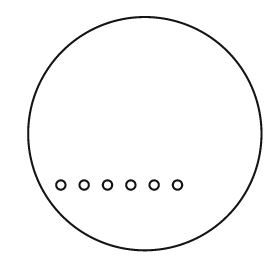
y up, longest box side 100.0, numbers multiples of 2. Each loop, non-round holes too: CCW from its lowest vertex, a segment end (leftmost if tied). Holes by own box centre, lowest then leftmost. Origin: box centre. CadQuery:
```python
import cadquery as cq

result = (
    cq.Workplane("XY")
    .moveTo(0.0, 0.0)
    .circle(50.0)
    .moveTo(-36.0, -22.0)
    .circle(2.0)
    .moveTo(-26.0, -22.0)
    .circle(2.0)
    .moveTo(-16.0, -22.0)
    .circle(2.0)
    .moveTo(-6.0, -22.0)
    .circle(2.0)
    .moveTo(4.0, -22.0)
    .circle(2.0)
    .moveTo(14.0, -22.0)
    .circle(2.0)
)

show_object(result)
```